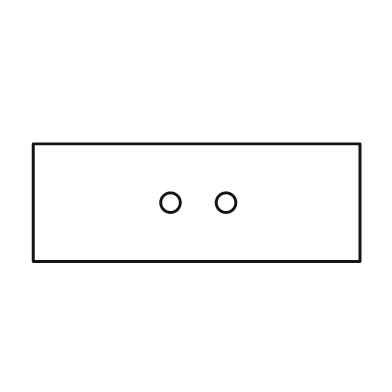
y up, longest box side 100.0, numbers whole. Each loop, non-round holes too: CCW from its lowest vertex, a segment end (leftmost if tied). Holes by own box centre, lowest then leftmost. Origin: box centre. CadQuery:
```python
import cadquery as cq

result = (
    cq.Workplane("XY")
    .moveTo(-50.0, -18.0)
    .lineTo(50.0, -18.0)
    .lineTo(50.0, 18.0)
    .lineTo(-50.0, 18.0)
    .close()
    .moveTo(-8.0, 0.0)
    .circle(3.0)
    .moveTo(9.0, 0.0)
    .circle(3.0)
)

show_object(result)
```